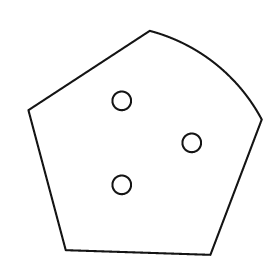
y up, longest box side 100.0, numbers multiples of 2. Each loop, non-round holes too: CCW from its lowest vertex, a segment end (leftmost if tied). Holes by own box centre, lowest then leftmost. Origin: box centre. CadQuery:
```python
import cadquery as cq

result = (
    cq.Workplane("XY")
    .moveTo(28.0, -48.0)
    .lineTo(50.0, 10.0)
    .threePointArc((30.0, 34.0), (2.0, 48.0))
    .lineTo(-50.0, 14.0)
    .lineTo(-34.0, -46.0)
    .close()
    .moveTo(-10.0, -18.0)
    .circle(4.0)
    .moveTo(20.0, 0.0)
    .circle(4.0)
    .moveTo(-10.0, 18.0)
    .circle(4.0)
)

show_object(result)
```